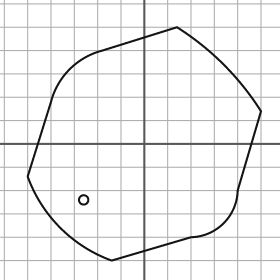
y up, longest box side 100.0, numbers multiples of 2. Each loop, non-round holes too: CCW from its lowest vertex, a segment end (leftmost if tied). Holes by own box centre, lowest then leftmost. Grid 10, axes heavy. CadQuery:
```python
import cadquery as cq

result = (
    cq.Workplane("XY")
    .moveTo(-14.0, -50.0)
    .lineTo(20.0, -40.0)
    .threePointArc((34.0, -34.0), (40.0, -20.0))
    .lineTo(50.0, 14.0)
    .threePointArc((34.0, 34.0), (14.0, 50.0))
    .lineTo(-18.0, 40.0)
    .threePointArc((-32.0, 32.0), (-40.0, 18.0))
    .lineTo(-50.0, -14.0)
    .threePointArc((-36.0, -36.0), (-14.0, -50.0))
    .close()
    .moveTo(-26.0, -24.0)
    .circle(2.0)
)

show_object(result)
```